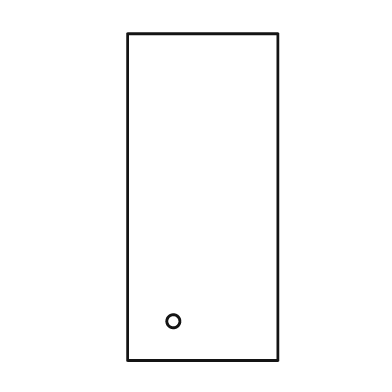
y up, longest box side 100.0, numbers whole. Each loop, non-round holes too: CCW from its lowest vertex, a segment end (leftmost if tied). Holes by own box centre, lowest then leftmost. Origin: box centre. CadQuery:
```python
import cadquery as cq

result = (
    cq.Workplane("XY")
    .moveTo(-23.0, -50.0)
    .lineTo(23.0, -50.0)
    .lineTo(23.0, 50.0)
    .lineTo(-23.0, 50.0)
    .close()
    .moveTo(-9.0, -38.0)
    .circle(2.0)
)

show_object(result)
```